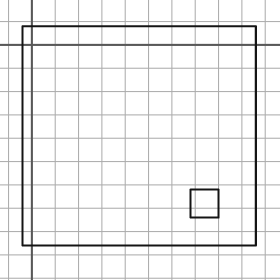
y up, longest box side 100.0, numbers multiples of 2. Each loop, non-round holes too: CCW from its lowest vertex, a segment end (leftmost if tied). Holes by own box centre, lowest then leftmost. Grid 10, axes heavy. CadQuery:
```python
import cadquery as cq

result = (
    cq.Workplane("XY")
    .moveTo(-4.0, -86.0)
    .lineTo(96.0, -86.0)
    .lineTo(96.0, 8.0)
    .lineTo(-4.0, 8.0)
    .close()
    .moveTo(68.0, -74.0)
    .lineTo(80.0, -74.0)
    .lineTo(80.0, -62.0)
    .lineTo(68.0, -62.0)
    .close()
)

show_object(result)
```